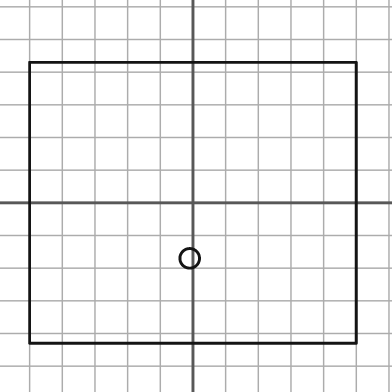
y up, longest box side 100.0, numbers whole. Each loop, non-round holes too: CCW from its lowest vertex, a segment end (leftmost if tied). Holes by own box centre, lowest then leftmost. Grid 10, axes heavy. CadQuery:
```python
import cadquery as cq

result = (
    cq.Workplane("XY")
    .moveTo(-50.0, -43.0)
    .lineTo(50.0, -43.0)
    .lineTo(50.0, 43.0)
    .lineTo(-50.0, 43.0)
    .close()
    .moveTo(-1.0, -17.0)
    .circle(3.0)
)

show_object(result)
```